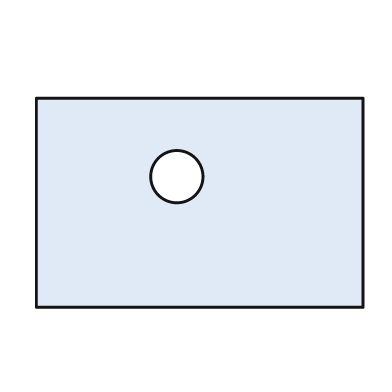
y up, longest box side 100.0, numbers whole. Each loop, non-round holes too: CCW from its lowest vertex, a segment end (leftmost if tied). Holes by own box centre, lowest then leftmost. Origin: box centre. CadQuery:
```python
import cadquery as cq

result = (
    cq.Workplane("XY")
    .moveTo(-50.0, -32.0)
    .lineTo(50.0, -32.0)
    .lineTo(50.0, 32.0)
    .lineTo(-50.0, 32.0)
    .close()
    .moveTo(-7.0, 8.0)
    .circle(8.0)
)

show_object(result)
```